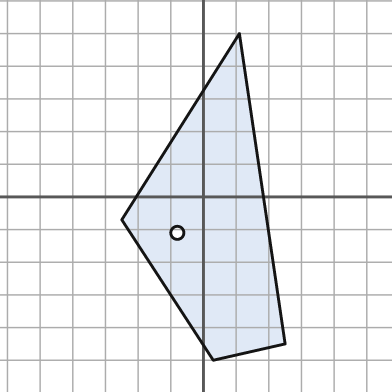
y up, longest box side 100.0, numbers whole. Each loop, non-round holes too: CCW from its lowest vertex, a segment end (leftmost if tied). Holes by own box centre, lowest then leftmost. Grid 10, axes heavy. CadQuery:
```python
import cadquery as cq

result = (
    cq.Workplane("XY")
    .moveTo(3.0, -50.0)
    .lineTo(25.0, -45.0)
    .lineTo(11.0, 50.0)
    .lineTo(-25.0, -7.0)
    .close()
    .moveTo(-8.0, -11.0)
    .circle(2.0)
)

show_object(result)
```